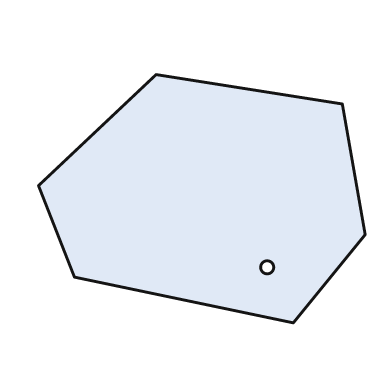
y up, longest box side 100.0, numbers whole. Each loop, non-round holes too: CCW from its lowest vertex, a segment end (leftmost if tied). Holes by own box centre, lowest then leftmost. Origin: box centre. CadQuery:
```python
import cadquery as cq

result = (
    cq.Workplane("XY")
    .moveTo(28.0, -38.0)
    .lineTo(50.0, -11.0)
    .lineTo(43.0, 29.0)
    .lineTo(-14.0, 38.0)
    .lineTo(-50.0, 4.0)
    .lineTo(-39.0, -24.0)
    .close()
    .moveTo(20.0, -21.0)
    .circle(2.0)
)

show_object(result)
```